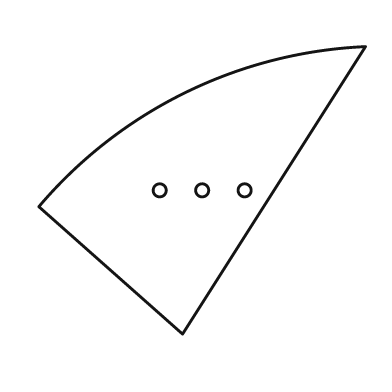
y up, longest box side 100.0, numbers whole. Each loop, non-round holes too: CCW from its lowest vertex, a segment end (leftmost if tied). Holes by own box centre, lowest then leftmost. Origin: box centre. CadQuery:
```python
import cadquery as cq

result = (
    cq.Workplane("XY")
    .moveTo(-6.0, -44.0)
    .lineTo(50.0, 44.0)
    .threePointArc((-5.0, 30.0), (-50.0, -5.0))
    .close()
    .moveTo(-13.0, 0.0)
    .circle(2.0)
    .moveTo(0.0, 0.0)
    .circle(2.0)
    .moveTo(13.0, 0.0)
    .circle(2.0)
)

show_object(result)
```